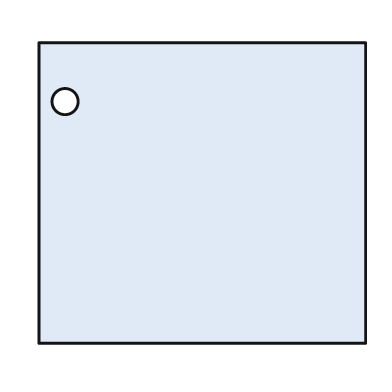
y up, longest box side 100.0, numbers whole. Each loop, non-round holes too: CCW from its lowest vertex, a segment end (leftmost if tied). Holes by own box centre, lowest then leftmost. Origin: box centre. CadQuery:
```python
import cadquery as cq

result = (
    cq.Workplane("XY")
    .moveTo(-50.0, -46.0)
    .lineTo(50.0, -46.0)
    .lineTo(50.0, 46.0)
    .lineTo(-50.0, 46.0)
    .close()
    .moveTo(-42.0, 28.0)
    .circle(4.0)
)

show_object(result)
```